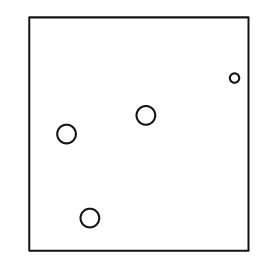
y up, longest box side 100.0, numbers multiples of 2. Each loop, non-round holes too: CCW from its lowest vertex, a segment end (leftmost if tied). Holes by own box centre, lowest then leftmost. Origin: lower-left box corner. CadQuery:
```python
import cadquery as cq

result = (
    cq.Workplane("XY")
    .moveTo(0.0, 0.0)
    .lineTo(94.0, 0.0)
    .lineTo(94.0, 100.0)
    .lineTo(0.0, 100.0)
    .close()
    .moveTo(26.0, 14.0)
    .circle(4.0)
    .moveTo(16.0, 50.0)
    .circle(4.0)
    .moveTo(50.0, 58.0)
    .circle(4.0)
    .moveTo(88.0, 74.0)
    .circle(2.0)
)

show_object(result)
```